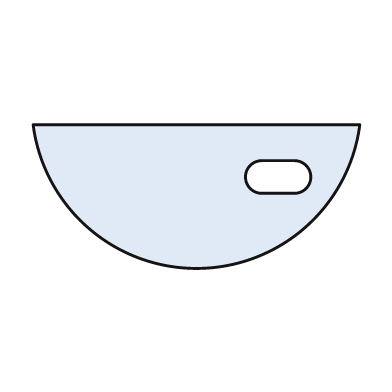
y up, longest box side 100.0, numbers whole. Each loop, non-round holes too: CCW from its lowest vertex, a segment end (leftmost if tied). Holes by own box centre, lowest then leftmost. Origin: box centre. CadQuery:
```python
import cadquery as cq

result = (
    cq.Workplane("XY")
    .moveTo(-50.0, 22.0)
    .threePointArc((0.0, -22.0), (50.0, 22.0))
    .close()
    .moveTo(20.0, 1.0)
    .lineTo(30.0, 1.0)
    .threePointArc((35.0, 6.0), (30.0, 11.0))
    .lineTo(20.0, 11.0)
    .threePointArc((15.0, 6.0), (20.0, 1.0))
    .close()
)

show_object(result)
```